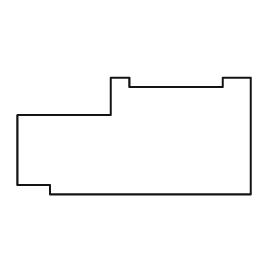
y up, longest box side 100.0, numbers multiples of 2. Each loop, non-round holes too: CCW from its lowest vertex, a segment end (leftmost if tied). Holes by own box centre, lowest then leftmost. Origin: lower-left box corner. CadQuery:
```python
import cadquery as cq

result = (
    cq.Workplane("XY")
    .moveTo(14.0, 0.0)
    .lineTo(100.0, 0.0)
    .lineTo(100.0, 50.0)
    .lineTo(88.0, 50.0)
    .lineTo(88.0, 46.0)
    .lineTo(48.0, 46.0)
    .lineTo(48.0, 50.0)
    .lineTo(40.0, 50.0)
    .lineTo(40.0, 34.0)
    .lineTo(0.0, 34.0)
    .lineTo(0.0, 4.0)
    .lineTo(14.0, 4.0)
    .close()
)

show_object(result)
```